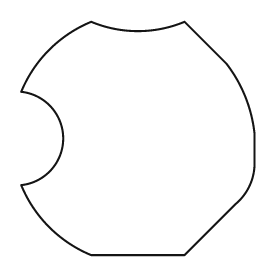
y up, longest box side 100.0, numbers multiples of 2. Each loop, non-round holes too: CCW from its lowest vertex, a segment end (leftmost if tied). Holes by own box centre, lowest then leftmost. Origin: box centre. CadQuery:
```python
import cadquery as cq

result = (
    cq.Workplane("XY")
    .moveTo(-20.0, -50.0)
    .lineTo(20.0, -50.0)
    .lineTo(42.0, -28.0)
    .threePointArc((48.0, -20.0), (50.0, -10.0))
    .lineTo(50.0, 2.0)
    .threePointArc((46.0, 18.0), (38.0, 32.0))
    .lineTo(20.0, 50.0)
    .threePointArc((0.0, 46.0), (-20.0, 50.0))
    .threePointArc((-38.0, 38.0), (-50.0, 20.0))
    .threePointArc((-32.0, 0.0), (-50.0, -20.0))
    .threePointArc((-38.0, -38.0), (-20.0, -50.0))
    .close()
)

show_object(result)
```